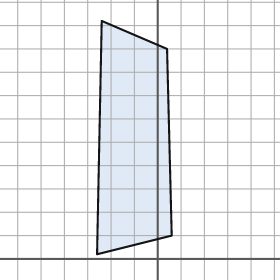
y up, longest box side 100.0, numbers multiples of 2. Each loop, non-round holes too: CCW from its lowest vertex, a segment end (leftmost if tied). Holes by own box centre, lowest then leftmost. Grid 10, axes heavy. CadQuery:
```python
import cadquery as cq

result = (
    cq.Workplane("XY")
    .moveTo(-26.0, 2.0)
    .lineTo(6.0, 10.0)
    .lineTo(4.0, 90.0)
    .lineTo(-24.0, 102.0)
    .close()
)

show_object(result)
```